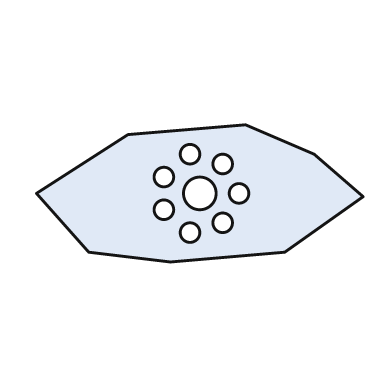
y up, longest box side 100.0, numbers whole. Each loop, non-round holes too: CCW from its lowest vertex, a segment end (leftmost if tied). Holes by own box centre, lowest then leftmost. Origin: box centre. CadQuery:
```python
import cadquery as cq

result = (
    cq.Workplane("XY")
    .moveTo(-9.0, -21.0)
    .lineTo(26.0, -18.0)
    .lineTo(50.0, -1.0)
    .lineTo(35.0, 12.0)
    .lineTo(14.0, 21.0)
    .lineTo(-22.0, 18.0)
    .lineTo(-50.0, 0.0)
    .lineTo(-34.0, -18.0)
    .close()
    .moveTo(-3.0, -12.0)
    .circle(3.0)
    .moveTo(7.0, -9.0)
    .circle(3.0)
    .moveTo(-11.0, -5.0)
    .circle(3.0)
    .moveTo(0.0, 0.0)
    .circle(5.0)
    .moveTo(12.0, 0.0)
    .circle(3.0)
    .moveTo(-11.0, 5.0)
    .circle(3.0)
    .moveTo(7.0, 9.0)
    .circle(3.0)
    .moveTo(-3.0, 12.0)
    .circle(3.0)
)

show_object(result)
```